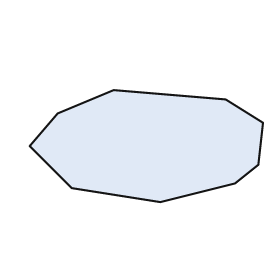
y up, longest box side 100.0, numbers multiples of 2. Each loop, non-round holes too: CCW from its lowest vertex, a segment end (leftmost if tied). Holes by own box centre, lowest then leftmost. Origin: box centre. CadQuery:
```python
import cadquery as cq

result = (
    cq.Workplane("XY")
    .moveTo(6.0, -24.0)
    .lineTo(38.0, -16.0)
    .lineTo(48.0, -8.0)
    .lineTo(50.0, 10.0)
    .lineTo(34.0, 20.0)
    .lineTo(-14.0, 24.0)
    .lineTo(-38.0, 14.0)
    .lineTo(-50.0, 0.0)
    .lineTo(-32.0, -18.0)
    .close()
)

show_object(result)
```